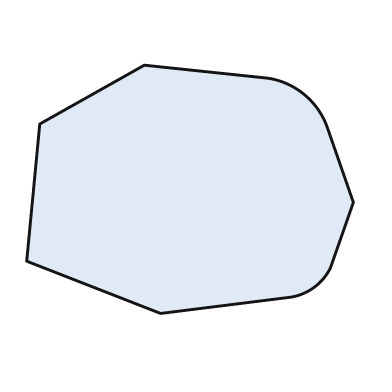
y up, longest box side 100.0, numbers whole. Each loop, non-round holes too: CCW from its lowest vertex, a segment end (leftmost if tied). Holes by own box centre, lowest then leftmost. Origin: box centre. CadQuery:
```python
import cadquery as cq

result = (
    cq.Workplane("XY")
    .moveTo(-9.0, -38.0)
    .lineTo(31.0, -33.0)
    .threePointArc((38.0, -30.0), (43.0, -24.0))
    .lineTo(50.0, -4.0)
    .lineTo(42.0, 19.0)
    .threePointArc((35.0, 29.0), (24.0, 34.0))
    .lineTo(-14.0, 38.0)
    .lineTo(-46.0, 20.0)
    .lineTo(-50.0, -22.0)
    .close()
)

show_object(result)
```